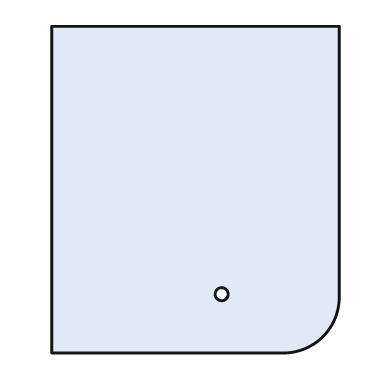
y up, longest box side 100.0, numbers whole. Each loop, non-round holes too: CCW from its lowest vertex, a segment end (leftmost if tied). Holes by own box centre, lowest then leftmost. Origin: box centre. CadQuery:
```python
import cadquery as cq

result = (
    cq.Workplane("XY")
    .moveTo(-44.0, -50.0)
    .lineTo(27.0, -50.0)
    .threePointArc((39.0, -45.0), (44.0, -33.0))
    .lineTo(44.0, 50.0)
    .lineTo(-44.0, 50.0)
    .close()
    .moveTo(8.0, -32.0)
    .circle(2.0)
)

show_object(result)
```